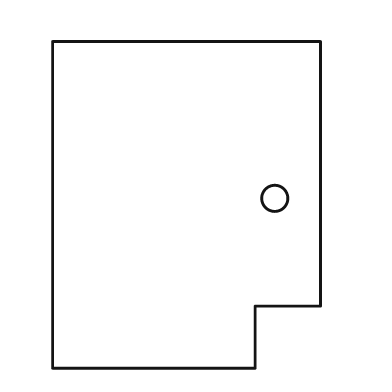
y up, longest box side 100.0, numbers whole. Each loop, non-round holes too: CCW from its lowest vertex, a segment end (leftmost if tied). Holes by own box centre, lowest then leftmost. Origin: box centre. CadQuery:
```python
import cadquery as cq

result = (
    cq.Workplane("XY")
    .moveTo(-41.0, -50.0)
    .lineTo(21.0, -50.0)
    .lineTo(21.0, -31.0)
    .lineTo(41.0, -31.0)
    .lineTo(41.0, 50.0)
    .lineTo(-41.0, 50.0)
    .close()
    .moveTo(27.0, 2.0)
    .circle(4.0)
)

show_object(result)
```